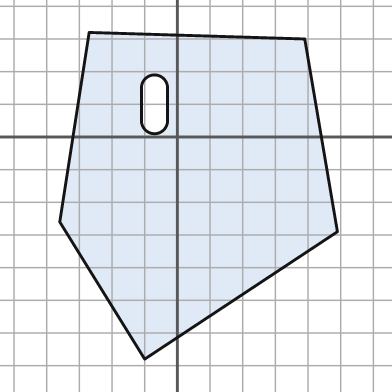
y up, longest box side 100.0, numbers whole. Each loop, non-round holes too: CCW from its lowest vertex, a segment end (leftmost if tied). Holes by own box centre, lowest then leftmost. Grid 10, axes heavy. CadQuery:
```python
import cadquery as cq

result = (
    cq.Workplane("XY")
    .moveTo(-10.0, -68.0)
    .lineTo(49.0, -29.0)
    .lineTo(39.0, 30.0)
    .lineTo(-27.0, 32.0)
    .lineTo(-36.0, -26.0)
    .close()
    .moveTo(-11.0, 5.0)
    .threePointArc((-7.0, 1.0), (-3.0, 5.0))
    .lineTo(-3.0, 15.0)
    .threePointArc((-7.0, 19.0), (-11.0, 15.0))
    .close()
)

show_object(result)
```